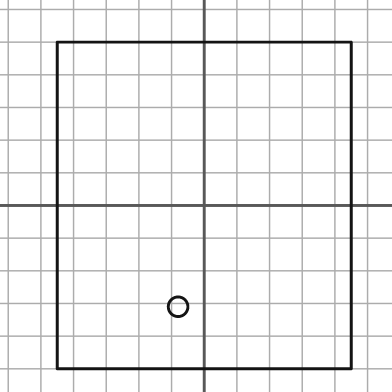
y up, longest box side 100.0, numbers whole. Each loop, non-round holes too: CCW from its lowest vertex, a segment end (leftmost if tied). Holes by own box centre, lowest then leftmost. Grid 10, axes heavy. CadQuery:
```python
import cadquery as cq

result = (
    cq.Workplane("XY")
    .moveTo(-45.0, -50.0)
    .lineTo(45.0, -50.0)
    .lineTo(45.0, 50.0)
    .lineTo(-45.0, 50.0)
    .close()
    .moveTo(-8.0, -31.0)
    .circle(3.0)
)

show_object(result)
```